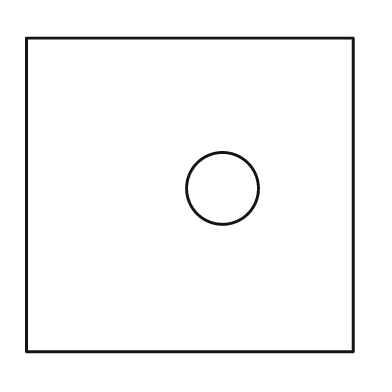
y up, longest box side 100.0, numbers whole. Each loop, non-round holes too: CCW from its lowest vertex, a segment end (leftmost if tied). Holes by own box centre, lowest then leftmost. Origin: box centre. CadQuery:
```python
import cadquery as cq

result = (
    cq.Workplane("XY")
    .moveTo(-50.0, -48.0)
    .lineTo(50.0, -48.0)
    .lineTo(50.0, 48.0)
    .lineTo(-50.0, 48.0)
    .close()
    .moveTo(10.0, 2.0)
    .circle(11.0)
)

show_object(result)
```